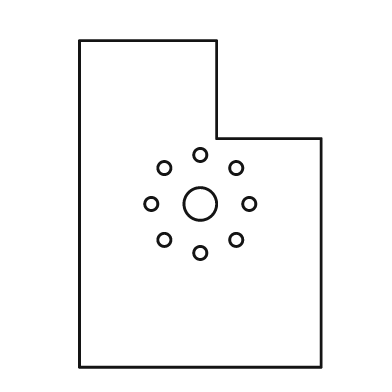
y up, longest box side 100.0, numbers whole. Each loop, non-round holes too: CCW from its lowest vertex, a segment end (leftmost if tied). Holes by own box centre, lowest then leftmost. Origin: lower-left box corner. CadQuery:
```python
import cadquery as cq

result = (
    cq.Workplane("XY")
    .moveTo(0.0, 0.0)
    .lineTo(74.0, 0.0)
    .lineTo(74.0, 70.0)
    .lineTo(42.0, 70.0)
    .lineTo(42.0, 100.0)
    .lineTo(0.0, 100.0)
    .close()
    .moveTo(37.0, 35.0)
    .circle(2.0)
    .moveTo(26.0, 39.0)
    .circle(2.0)
    .moveTo(48.0, 39.0)
    .circle(2.0)
    .moveTo(22.0, 50.0)
    .circle(2.0)
    .moveTo(37.0, 50.0)
    .circle(5.0)
    .moveTo(52.0, 50.0)
    .circle(2.0)
    .moveTo(26.0, 61.0)
    .circle(2.0)
    .moveTo(48.0, 61.0)
    .circle(2.0)
    .moveTo(37.0, 65.0)
    .circle(2.0)
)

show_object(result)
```